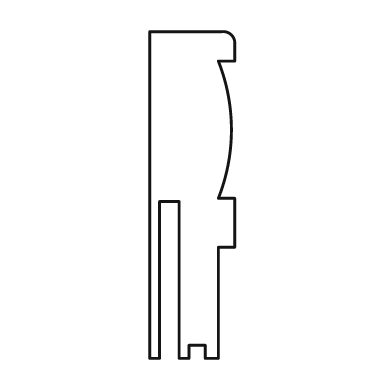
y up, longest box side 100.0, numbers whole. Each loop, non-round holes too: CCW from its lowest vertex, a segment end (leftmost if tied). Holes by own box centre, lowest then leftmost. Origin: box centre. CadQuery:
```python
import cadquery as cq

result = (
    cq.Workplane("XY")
    .moveTo(-13.0, -50.0)
    .lineTo(-10.0, -50.0)
    .lineTo(-10.0, -2.0)
    .lineTo(-4.0, -2.0)
    .lineTo(-4.0, -50.0)
    .lineTo(-1.0, -50.0)
    .lineTo(-1.0, -46.0)
    .lineTo(4.0, -46.0)
    .lineTo(4.0, -50.0)
    .lineTo(8.0, -50.0)
    .lineTo(8.0, -16.0)
    .lineTo(13.0, -16.0)
    .lineTo(13.0, -1.0)
    .lineTo(8.0, -1.0)
    .threePointArc((12.0, 20.0), (8.0, 41.0))
    .lineTo(13.0, 41.0)
    .lineTo(13.0, 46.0)
    .threePointArc((12.0, 49.0), (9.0, 50.0))
    .lineTo(-13.0, 50.0)
    .close()
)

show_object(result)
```